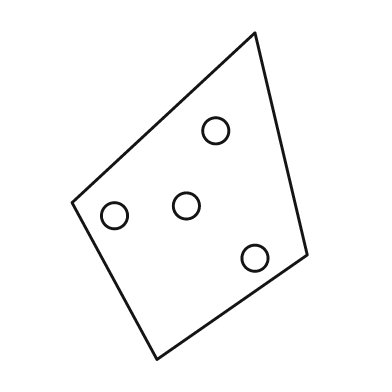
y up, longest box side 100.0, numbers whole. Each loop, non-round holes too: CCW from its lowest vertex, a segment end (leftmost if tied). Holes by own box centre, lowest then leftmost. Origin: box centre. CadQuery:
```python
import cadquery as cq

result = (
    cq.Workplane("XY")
    .moveTo(-10.0, -50.0)
    .lineTo(36.0, -18.0)
    .lineTo(20.0, 50.0)
    .lineTo(-36.0, -2.0)
    .close()
    .moveTo(20.0, -19.0)
    .circle(4.0)
    .moveTo(-23.0, -6.0)
    .circle(4.0)
    .moveTo(-1.0, -3.0)
    .circle(4.0)
    .moveTo(8.0, 20.0)
    .circle(4.0)
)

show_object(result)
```